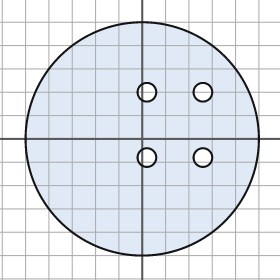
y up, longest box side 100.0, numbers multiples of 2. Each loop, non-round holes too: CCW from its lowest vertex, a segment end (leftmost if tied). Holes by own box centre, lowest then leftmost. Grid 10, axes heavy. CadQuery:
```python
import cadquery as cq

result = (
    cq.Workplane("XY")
    .moveTo(0.0, 0.0)
    .circle(50.0)
    .moveTo(2.0, -8.0)
    .circle(4.0)
    .moveTo(26.0, -8.0)
    .circle(4.0)
    .moveTo(2.0, 20.0)
    .circle(4.0)
    .moveTo(26.0, 20.0)
    .circle(4.0)
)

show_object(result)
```